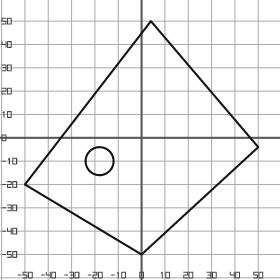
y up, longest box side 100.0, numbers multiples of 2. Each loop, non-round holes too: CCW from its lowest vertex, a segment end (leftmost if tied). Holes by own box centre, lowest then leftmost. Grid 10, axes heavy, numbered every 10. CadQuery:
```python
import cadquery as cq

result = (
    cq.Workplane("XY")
    .moveTo(0.0, -50.0)
    .lineTo(50.0, -4.0)
    .lineTo(4.0, 50.0)
    .lineTo(-50.0, -20.0)
    .close()
    .moveTo(-18.0, -10.0)
    .circle(6.0)
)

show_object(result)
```